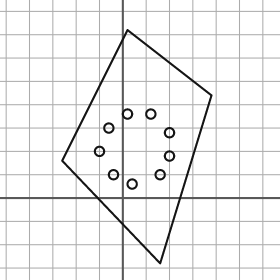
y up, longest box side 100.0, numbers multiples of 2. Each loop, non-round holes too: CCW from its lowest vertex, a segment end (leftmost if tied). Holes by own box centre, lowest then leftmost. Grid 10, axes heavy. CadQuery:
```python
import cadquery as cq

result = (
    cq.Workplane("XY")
    .moveTo(16.0, -28.0)
    .lineTo(38.0, 44.0)
    .lineTo(2.0, 72.0)
    .lineTo(-26.0, 16.0)
    .close()
    .moveTo(4.0, 6.0)
    .circle(2.0)
    .moveTo(-4.0, 10.0)
    .circle(2.0)
    .moveTo(16.0, 10.0)
    .circle(2.0)
    .moveTo(20.0, 18.0)
    .circle(2.0)
    .moveTo(-10.0, 20.0)
    .circle(2.0)
    .moveTo(20.0, 28.0)
    .circle(2.0)
    .moveTo(-6.0, 30.0)
    .circle(2.0)
    .moveTo(2.0, 36.0)
    .circle(2.0)
    .moveTo(12.0, 36.0)
    .circle(2.0)
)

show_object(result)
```